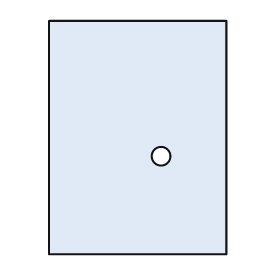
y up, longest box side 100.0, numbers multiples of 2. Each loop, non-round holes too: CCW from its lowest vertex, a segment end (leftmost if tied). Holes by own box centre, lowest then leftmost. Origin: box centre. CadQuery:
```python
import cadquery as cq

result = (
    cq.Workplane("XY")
    .moveTo(-38.0, -50.0)
    .lineTo(38.0, -50.0)
    .lineTo(38.0, 50.0)
    .lineTo(-38.0, 50.0)
    .close()
    .moveTo(10.0, -8.0)
    .circle(4.0)
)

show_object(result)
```